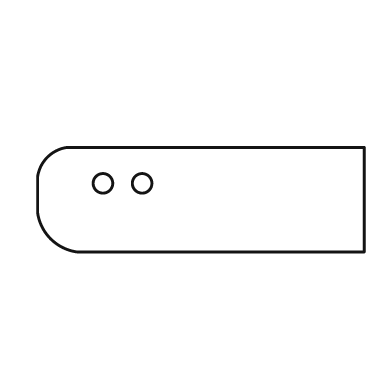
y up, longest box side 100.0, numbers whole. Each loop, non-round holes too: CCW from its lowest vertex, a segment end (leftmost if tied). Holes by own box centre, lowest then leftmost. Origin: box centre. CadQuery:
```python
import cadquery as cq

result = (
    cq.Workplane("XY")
    .moveTo(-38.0, -16.0)
    .lineTo(50.0, -16.0)
    .lineTo(50.0, 16.0)
    .lineTo(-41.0, 16.0)
    .threePointArc((-47.0, 13.0), (-50.0, 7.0))
    .lineTo(-50.0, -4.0)
    .threePointArc((-46.0, -12.0), (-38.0, -16.0))
    .close()
    .moveTo(-30.0, 5.0)
    .circle(3.0)
    .moveTo(-18.0, 5.0)
    .circle(3.0)
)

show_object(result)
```